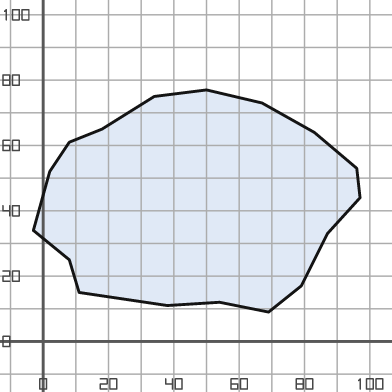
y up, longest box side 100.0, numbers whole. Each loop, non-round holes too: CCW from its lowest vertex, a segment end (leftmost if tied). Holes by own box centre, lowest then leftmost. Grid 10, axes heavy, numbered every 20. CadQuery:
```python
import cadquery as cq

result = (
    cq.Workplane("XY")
    .moveTo(69.0, 9.0)
    .lineTo(79.0, 17.0)
    .lineTo(87.0, 33.0)
    .lineTo(97.0, 44.0)
    .lineTo(96.0, 53.0)
    .lineTo(83.0, 64.0)
    .lineTo(67.0, 73.0)
    .lineTo(50.0, 77.0)
    .lineTo(34.0, 75.0)
    .lineTo(18.0, 65.0)
    .lineTo(8.0, 61.0)
    .lineTo(2.0, 52.0)
    .lineTo(-3.0, 34.0)
    .lineTo(8.0, 25.0)
    .lineTo(11.0, 15.0)
    .lineTo(38.0, 11.0)
    .lineTo(54.0, 12.0)
    .close()
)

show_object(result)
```